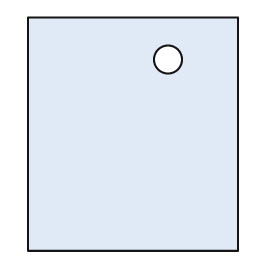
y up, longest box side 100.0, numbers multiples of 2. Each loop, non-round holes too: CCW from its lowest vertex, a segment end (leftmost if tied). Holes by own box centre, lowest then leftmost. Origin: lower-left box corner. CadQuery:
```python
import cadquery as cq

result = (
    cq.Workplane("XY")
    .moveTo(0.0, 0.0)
    .lineTo(90.0, 0.0)
    .lineTo(90.0, 100.0)
    .lineTo(0.0, 100.0)
    .close()
    .moveTo(60.0, 82.0)
    .circle(6.0)
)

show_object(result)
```